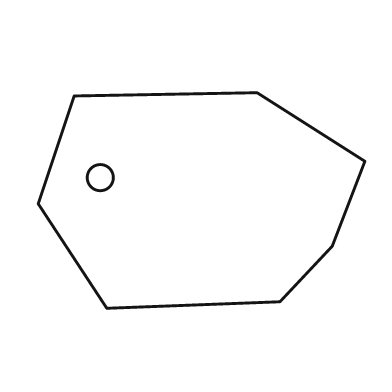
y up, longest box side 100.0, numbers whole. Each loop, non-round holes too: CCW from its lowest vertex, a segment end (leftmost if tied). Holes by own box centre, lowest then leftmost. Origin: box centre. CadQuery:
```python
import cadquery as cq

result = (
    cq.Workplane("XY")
    .moveTo(-29.0, -33.0)
    .lineTo(24.0, -31.0)
    .lineTo(40.0, -14.0)
    .lineTo(50.0, 12.0)
    .lineTo(17.0, 33.0)
    .lineTo(-39.0, 32.0)
    .lineTo(-50.0, -1.0)
    .close()
    .moveTo(-31.0, 7.0)
    .circle(4.0)
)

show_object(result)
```